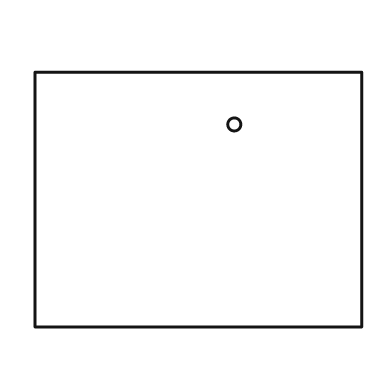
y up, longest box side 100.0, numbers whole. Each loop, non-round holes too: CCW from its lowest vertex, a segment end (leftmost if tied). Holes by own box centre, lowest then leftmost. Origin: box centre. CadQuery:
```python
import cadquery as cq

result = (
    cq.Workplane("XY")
    .moveTo(-50.0, -39.0)
    .lineTo(50.0, -39.0)
    .lineTo(50.0, 39.0)
    .lineTo(-50.0, 39.0)
    .close()
    .moveTo(11.0, 23.0)
    .circle(2.0)
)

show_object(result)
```